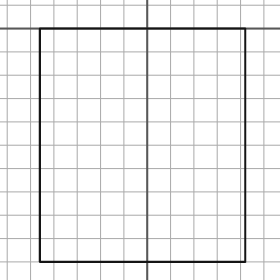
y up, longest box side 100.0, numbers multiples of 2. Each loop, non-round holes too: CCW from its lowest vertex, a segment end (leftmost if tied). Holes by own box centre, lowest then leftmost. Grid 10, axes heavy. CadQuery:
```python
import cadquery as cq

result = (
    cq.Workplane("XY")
    .moveTo(-46.0, -100.0)
    .lineTo(42.0, -100.0)
    .lineTo(42.0, 0.0)
    .lineTo(-46.0, 0.0)
    .close()
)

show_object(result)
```